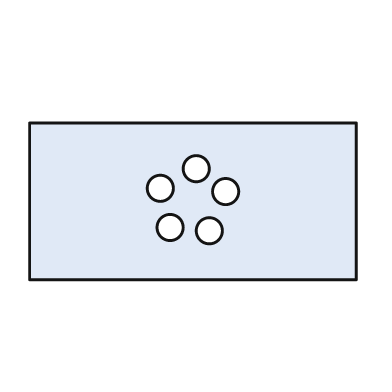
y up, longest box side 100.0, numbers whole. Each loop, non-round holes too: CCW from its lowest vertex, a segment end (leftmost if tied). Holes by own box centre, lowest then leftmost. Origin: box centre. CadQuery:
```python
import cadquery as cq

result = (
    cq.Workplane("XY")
    .moveTo(-50.0, -24.0)
    .lineTo(50.0, -24.0)
    .lineTo(50.0, 24.0)
    .lineTo(-50.0, 24.0)
    .close()
    .moveTo(5.0, -9.0)
    .circle(4.0)
    .moveTo(-7.0, -8.0)
    .circle(4.0)
    .moveTo(10.0, 3.0)
    .circle(4.0)
    .moveTo(-10.0, 4.0)
    .circle(4.0)
    .moveTo(1.0, 10.0)
    .circle(4.0)
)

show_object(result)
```